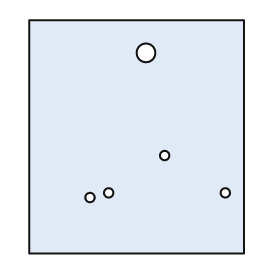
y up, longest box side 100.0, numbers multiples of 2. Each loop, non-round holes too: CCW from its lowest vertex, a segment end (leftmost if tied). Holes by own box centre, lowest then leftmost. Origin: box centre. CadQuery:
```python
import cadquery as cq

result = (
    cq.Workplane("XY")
    .moveTo(-46.0, -50.0)
    .lineTo(46.0, -50.0)
    .lineTo(46.0, 50.0)
    .lineTo(-46.0, 50.0)
    .close()
    .moveTo(-20.0, -26.0)
    .circle(2.0)
    .moveTo(-12.0, -24.0)
    .circle(2.0)
    .moveTo(38.0, -24.0)
    .circle(2.0)
    .moveTo(12.0, -8.0)
    .circle(2.0)
    .moveTo(4.0, 36.0)
    .circle(4.0)
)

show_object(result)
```